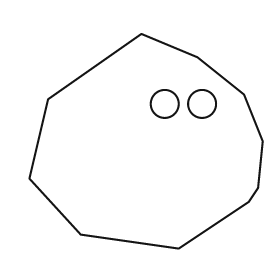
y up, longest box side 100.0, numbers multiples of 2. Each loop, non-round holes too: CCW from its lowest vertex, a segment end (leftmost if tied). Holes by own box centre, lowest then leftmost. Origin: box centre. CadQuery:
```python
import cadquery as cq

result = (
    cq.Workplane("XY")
    .moveTo(14.0, -46.0)
    .lineTo(44.0, -26.0)
    .lineTo(48.0, -20.0)
    .lineTo(50.0, 0.0)
    .lineTo(42.0, 20.0)
    .lineTo(22.0, 36.0)
    .lineTo(-2.0, 46.0)
    .lineTo(-42.0, 18.0)
    .lineTo(-50.0, -16.0)
    .lineTo(-28.0, -40.0)
    .close()
    .moveTo(8.0, 16.0)
    .circle(6.0)
    .moveTo(24.0, 16.0)
    .circle(6.0)
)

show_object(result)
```